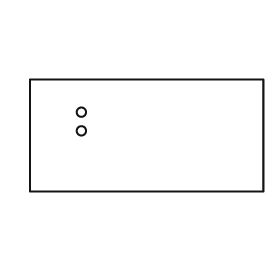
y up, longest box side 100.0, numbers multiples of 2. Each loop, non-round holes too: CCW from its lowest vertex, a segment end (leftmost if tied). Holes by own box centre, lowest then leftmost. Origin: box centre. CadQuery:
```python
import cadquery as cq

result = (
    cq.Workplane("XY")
    .moveTo(-50.0, -24.0)
    .lineTo(50.0, -24.0)
    .lineTo(50.0, 24.0)
    .lineTo(-50.0, 24.0)
    .close()
    .moveTo(-28.0, 2.0)
    .circle(2.0)
    .moveTo(-28.0, 10.0)
    .circle(2.0)
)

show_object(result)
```